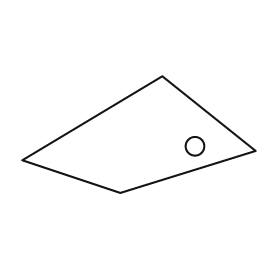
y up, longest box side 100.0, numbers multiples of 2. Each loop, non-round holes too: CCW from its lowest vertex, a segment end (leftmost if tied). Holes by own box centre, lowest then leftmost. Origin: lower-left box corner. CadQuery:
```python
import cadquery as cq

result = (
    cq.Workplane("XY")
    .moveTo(42.0, 0.0)
    .lineTo(100.0, 18.0)
    .lineTo(60.0, 50.0)
    .lineTo(0.0, 14.0)
    .close()
    .moveTo(74.0, 20.0)
    .circle(4.0)
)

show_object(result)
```